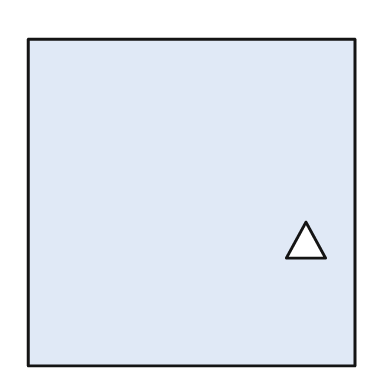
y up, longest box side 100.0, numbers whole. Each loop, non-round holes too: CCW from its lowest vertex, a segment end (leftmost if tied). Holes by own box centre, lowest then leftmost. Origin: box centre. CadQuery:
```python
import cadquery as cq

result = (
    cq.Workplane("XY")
    .moveTo(-50.0, -50.0)
    .lineTo(50.0, -50.0)
    .lineTo(50.0, 50.0)
    .lineTo(-50.0, 50.0)
    .close()
    .moveTo(29.0, -17.0)
    .lineTo(41.0, -17.0)
    .lineTo(35.0, -6.0)
    .close()
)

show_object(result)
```